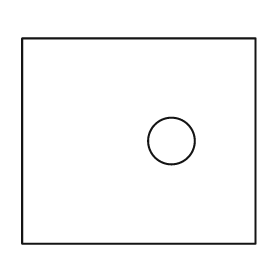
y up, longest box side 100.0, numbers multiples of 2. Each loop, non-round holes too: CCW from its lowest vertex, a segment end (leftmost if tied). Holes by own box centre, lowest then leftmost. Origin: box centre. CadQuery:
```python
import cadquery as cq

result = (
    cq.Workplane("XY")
    .moveTo(-50.0, -44.0)
    .lineTo(50.0, -44.0)
    .lineTo(50.0, 44.0)
    .lineTo(-50.0, 44.0)
    .close()
    .moveTo(14.0, 0.0)
    .circle(10.0)
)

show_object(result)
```